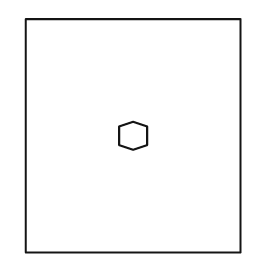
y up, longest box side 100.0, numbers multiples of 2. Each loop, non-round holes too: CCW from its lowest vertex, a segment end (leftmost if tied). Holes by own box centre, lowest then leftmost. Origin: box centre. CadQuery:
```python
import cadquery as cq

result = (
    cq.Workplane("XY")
    .moveTo(-46.0, -50.0)
    .lineTo(46.0, -50.0)
    .lineTo(46.0, 50.0)
    .lineTo(-46.0, 50.0)
    .close()
    .moveTo(0.0, -6.0)
    .lineTo(6.0, -4.0)
    .lineTo(6.0, 4.0)
    .lineTo(0.0, 6.0)
    .lineTo(-6.0, 4.0)
    .lineTo(-6.0, -4.0)
    .close()
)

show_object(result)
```